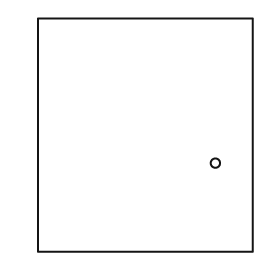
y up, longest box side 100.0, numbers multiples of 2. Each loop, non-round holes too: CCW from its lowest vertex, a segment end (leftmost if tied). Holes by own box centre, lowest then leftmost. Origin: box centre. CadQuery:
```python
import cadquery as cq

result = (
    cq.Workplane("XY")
    .moveTo(-46.0, -50.0)
    .lineTo(46.0, -50.0)
    .lineTo(46.0, 50.0)
    .lineTo(-46.0, 50.0)
    .close()
    .moveTo(30.0, -12.0)
    .circle(2.0)
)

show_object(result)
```